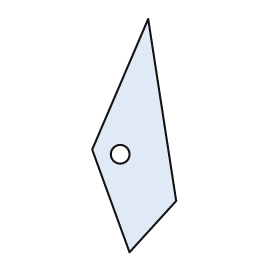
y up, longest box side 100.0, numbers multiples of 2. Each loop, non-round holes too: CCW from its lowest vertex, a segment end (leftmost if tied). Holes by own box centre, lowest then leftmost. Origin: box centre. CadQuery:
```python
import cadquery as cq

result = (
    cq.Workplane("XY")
    .moveTo(-2.0, -50.0)
    .lineTo(18.0, -28.0)
    .lineTo(6.0, 50.0)
    .lineTo(-18.0, -6.0)
    .close()
    .moveTo(-6.0, -8.0)
    .circle(4.0)
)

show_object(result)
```